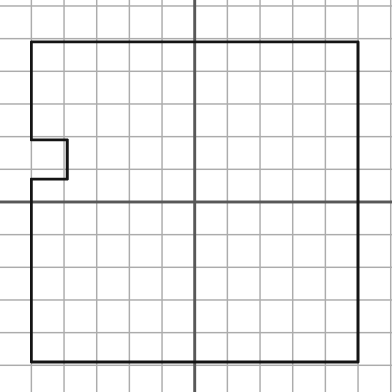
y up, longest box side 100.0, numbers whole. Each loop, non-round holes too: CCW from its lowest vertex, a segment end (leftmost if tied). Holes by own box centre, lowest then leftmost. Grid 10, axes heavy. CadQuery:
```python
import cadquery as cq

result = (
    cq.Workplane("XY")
    .moveTo(-50.0, -49.0)
    .lineTo(50.0, -49.0)
    .lineTo(50.0, 49.0)
    .lineTo(-50.0, 49.0)
    .lineTo(-50.0, 19.0)
    .lineTo(-39.0, 19.0)
    .lineTo(-39.0, 7.0)
    .lineTo(-50.0, 7.0)
    .close()
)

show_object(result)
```